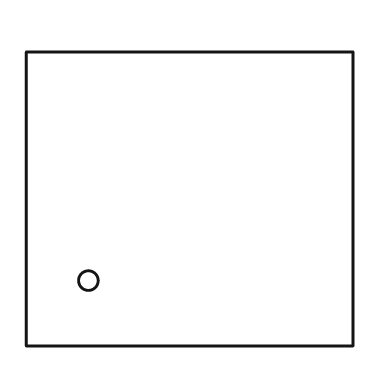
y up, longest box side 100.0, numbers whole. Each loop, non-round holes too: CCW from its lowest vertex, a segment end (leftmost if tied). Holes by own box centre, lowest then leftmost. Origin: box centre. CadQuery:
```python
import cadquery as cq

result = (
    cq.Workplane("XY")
    .moveTo(-50.0, -45.0)
    .lineTo(50.0, -45.0)
    .lineTo(50.0, 45.0)
    .lineTo(-50.0, 45.0)
    .close()
    .moveTo(-31.0, -25.0)
    .circle(3.0)
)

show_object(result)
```